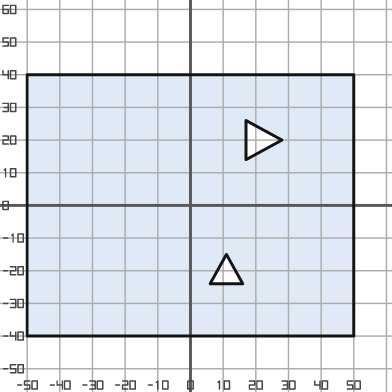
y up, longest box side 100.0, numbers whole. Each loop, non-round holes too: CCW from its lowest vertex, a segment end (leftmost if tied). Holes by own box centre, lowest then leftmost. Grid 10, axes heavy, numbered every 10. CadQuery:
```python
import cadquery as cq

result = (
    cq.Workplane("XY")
    .moveTo(-50.0, -40.0)
    .lineTo(50.0, -40.0)
    .lineTo(50.0, 40.0)
    .lineTo(-50.0, 40.0)
    .close()
    .moveTo(6.0, -24.0)
    .lineTo(16.0, -24.0)
    .lineTo(11.0, -15.0)
    .close()
    .moveTo(17.0, 14.0)
    .lineTo(28.0, 20.0)
    .lineTo(17.0, 26.0)
    .close()
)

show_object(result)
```